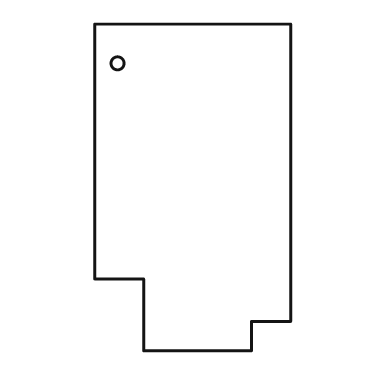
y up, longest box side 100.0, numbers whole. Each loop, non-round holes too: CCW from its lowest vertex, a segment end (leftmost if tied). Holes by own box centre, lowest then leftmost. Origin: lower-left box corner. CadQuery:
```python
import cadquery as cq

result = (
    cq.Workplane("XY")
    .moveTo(15.0, 0.0)
    .lineTo(48.0, 0.0)
    .lineTo(48.0, 9.0)
    .lineTo(60.0, 9.0)
    .lineTo(60.0, 100.0)
    .lineTo(0.0, 100.0)
    .lineTo(0.0, 22.0)
    .lineTo(15.0, 22.0)
    .close()
    .moveTo(7.0, 88.0)
    .circle(2.0)
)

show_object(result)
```